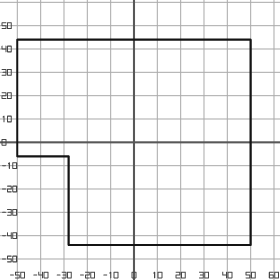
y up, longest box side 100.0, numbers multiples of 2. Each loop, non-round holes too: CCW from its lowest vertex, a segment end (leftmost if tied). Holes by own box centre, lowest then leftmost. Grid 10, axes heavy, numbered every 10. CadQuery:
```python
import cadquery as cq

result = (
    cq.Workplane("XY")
    .moveTo(-28.0, -44.0)
    .lineTo(50.0, -44.0)
    .lineTo(50.0, 44.0)
    .lineTo(-50.0, 44.0)
    .lineTo(-50.0, -6.0)
    .lineTo(-28.0, -6.0)
    .close()
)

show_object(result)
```